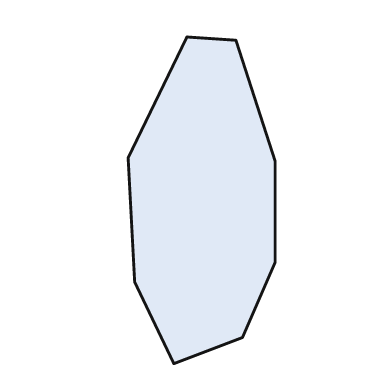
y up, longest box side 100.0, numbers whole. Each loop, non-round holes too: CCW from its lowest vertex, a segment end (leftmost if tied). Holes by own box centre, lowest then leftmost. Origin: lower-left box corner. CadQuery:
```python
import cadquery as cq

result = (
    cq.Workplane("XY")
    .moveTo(14.0, 0.0)
    .lineTo(35.0, 8.0)
    .lineTo(45.0, 31.0)
    .lineTo(45.0, 62.0)
    .lineTo(33.0, 99.0)
    .lineTo(18.0, 100.0)
    .lineTo(0.0, 63.0)
    .lineTo(2.0, 25.0)
    .close()
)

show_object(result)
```